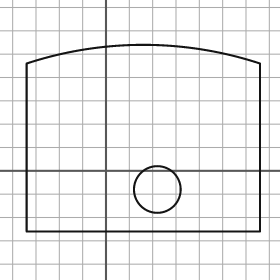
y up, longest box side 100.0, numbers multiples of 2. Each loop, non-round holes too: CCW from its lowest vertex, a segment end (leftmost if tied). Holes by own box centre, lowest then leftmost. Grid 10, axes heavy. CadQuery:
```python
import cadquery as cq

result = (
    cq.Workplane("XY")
    .moveTo(-34.0, -26.0)
    .lineTo(66.0, -26.0)
    .lineTo(66.0, 46.0)
    .threePointArc((16.0, 54.0), (-34.0, 46.0))
    .close()
    .moveTo(22.0, -8.0)
    .circle(10.0)
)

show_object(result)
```